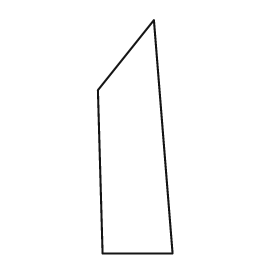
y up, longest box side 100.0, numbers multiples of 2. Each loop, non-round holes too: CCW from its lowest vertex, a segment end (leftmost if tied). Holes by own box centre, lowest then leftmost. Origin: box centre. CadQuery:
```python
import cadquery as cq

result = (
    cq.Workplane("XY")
    .moveTo(-14.0, -50.0)
    .lineTo(16.0, -50.0)
    .lineTo(8.0, 50.0)
    .lineTo(-16.0, 20.0)
    .close()
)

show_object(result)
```